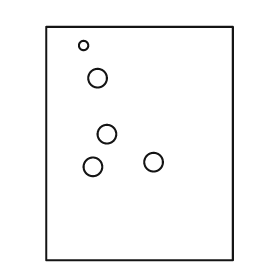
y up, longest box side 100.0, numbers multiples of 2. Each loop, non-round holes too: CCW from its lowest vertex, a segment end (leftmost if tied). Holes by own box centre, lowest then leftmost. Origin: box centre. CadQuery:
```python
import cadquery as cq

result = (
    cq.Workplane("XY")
    .moveTo(-40.0, -50.0)
    .lineTo(40.0, -50.0)
    .lineTo(40.0, 50.0)
    .lineTo(-40.0, 50.0)
    .close()
    .moveTo(-20.0, -10.0)
    .circle(4.0)
    .moveTo(6.0, -8.0)
    .circle(4.0)
    .moveTo(-14.0, 4.0)
    .circle(4.0)
    .moveTo(-18.0, 28.0)
    .circle(4.0)
    .moveTo(-24.0, 42.0)
    .circle(2.0)
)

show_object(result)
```